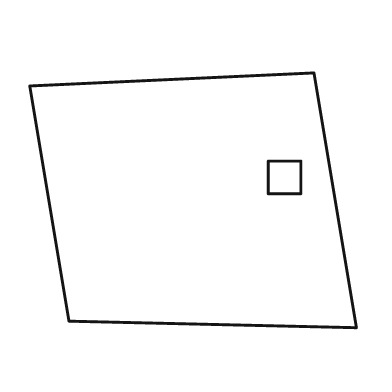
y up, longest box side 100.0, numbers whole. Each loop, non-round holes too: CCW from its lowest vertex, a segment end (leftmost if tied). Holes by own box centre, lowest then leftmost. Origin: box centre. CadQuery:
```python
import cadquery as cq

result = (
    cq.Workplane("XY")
    .moveTo(50.0, -39.0)
    .lineTo(37.0, 39.0)
    .lineTo(-50.0, 35.0)
    .lineTo(-38.0, -37.0)
    .close()
    .moveTo(23.0, 2.0)
    .lineTo(33.0, 2.0)
    .lineTo(33.0, 12.0)
    .lineTo(23.0, 12.0)
    .close()
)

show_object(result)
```